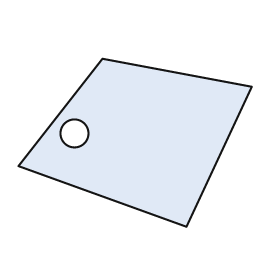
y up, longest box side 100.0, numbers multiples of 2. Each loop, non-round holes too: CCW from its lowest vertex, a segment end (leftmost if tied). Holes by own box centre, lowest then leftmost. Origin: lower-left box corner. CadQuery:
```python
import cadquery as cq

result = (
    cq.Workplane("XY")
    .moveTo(72.0, 0.0)
    .lineTo(100.0, 60.0)
    .lineTo(36.0, 72.0)
    .lineTo(0.0, 26.0)
    .close()
    .moveTo(24.0, 40.0)
    .circle(6.0)
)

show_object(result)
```